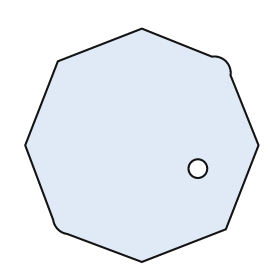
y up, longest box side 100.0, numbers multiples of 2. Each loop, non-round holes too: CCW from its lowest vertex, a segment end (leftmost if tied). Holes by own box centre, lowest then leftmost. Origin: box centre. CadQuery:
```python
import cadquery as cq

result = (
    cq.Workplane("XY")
    .moveTo(0.0, -50.0)
    .lineTo(36.0, -36.0)
    .lineTo(50.0, 0.0)
    .lineTo(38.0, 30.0)
    .threePointArc((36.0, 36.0), (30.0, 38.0))
    .lineTo(0.0, 50.0)
    .lineTo(-36.0, 36.0)
    .lineTo(-50.0, 0.0)
    .lineTo(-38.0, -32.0)
    .threePointArc((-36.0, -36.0), (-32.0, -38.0))
    .close()
    .moveTo(24.0, -10.0)
    .circle(4.0)
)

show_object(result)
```